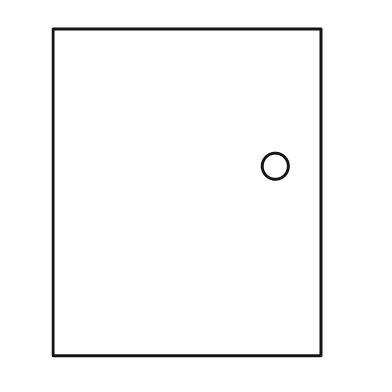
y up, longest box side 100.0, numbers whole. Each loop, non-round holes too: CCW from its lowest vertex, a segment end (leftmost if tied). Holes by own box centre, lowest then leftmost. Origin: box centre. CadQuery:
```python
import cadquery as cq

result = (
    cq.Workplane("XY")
    .moveTo(-41.0, -50.0)
    .lineTo(41.0, -50.0)
    .lineTo(41.0, 50.0)
    .lineTo(-41.0, 50.0)
    .close()
    .moveTo(27.0, 8.0)
    .circle(4.0)
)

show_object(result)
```